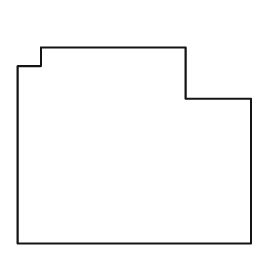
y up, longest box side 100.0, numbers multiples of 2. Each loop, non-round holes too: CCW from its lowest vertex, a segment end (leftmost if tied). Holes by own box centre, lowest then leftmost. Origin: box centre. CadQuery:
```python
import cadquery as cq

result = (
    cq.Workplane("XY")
    .moveTo(-50.0, -42.0)
    .lineTo(50.0, -42.0)
    .lineTo(50.0, 20.0)
    .lineTo(22.0, 20.0)
    .lineTo(22.0, 42.0)
    .lineTo(-40.0, 42.0)
    .lineTo(-40.0, 34.0)
    .lineTo(-50.0, 34.0)
    .close()
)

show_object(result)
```